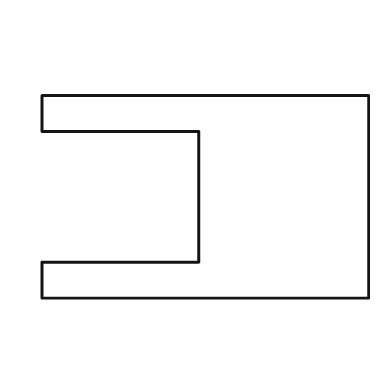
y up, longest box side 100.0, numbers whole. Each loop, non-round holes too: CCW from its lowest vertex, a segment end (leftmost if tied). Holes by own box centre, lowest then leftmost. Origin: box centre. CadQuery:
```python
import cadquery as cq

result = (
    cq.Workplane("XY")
    .moveTo(-50.0, -31.0)
    .lineTo(50.0, -31.0)
    .lineTo(50.0, 31.0)
    .lineTo(-50.0, 31.0)
    .lineTo(-50.0, 20.0)
    .lineTo(-2.0, 20.0)
    .lineTo(-2.0, -20.0)
    .lineTo(-50.0, -20.0)
    .close()
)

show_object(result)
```